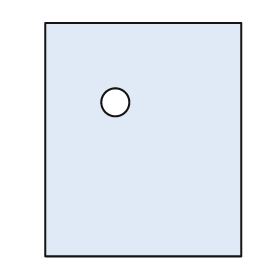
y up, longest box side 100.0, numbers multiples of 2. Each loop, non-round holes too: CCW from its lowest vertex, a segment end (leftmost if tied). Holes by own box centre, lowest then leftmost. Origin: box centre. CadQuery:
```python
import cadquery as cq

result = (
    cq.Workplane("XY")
    .moveTo(-42.0, -50.0)
    .lineTo(42.0, -50.0)
    .lineTo(42.0, 50.0)
    .lineTo(-42.0, 50.0)
    .close()
    .moveTo(-12.0, 16.0)
    .circle(6.0)
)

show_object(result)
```